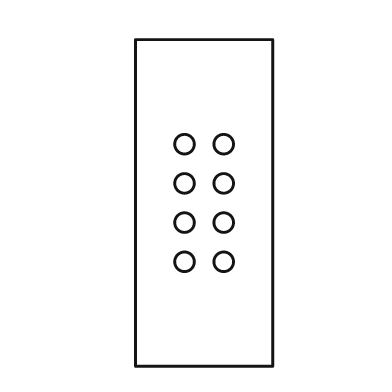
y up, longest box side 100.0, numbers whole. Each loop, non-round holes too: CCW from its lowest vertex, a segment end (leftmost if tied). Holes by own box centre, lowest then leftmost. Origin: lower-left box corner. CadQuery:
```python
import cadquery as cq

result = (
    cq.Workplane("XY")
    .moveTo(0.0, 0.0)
    .lineTo(42.0, 0.0)
    .lineTo(42.0, 100.0)
    .lineTo(0.0, 100.0)
    .close()
    .moveTo(15.0, 32.0)
    .circle(3.0)
    .moveTo(27.0, 32.0)
    .circle(3.0)
    .moveTo(15.0, 44.0)
    .circle(3.0)
    .moveTo(27.0, 44.0)
    .circle(3.0)
    .moveTo(15.0, 56.0)
    .circle(3.0)
    .moveTo(27.0, 56.0)
    .circle(3.0)
    .moveTo(15.0, 68.0)
    .circle(3.0)
    .moveTo(27.0, 68.0)
    .circle(3.0)
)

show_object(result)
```